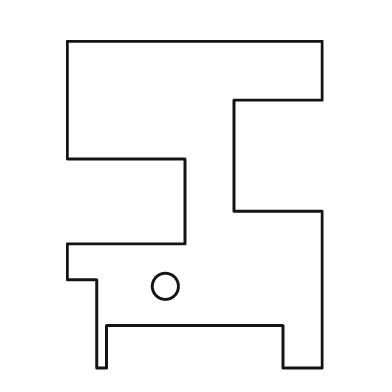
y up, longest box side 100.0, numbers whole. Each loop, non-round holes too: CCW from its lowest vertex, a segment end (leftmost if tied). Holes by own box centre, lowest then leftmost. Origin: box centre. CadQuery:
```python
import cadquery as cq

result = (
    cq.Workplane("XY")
    .moveTo(-30.0, -50.0)
    .lineTo(-27.0, -50.0)
    .lineTo(-27.0, -37.0)
    .lineTo(27.0, -37.0)
    .lineTo(27.0, -50.0)
    .lineTo(39.0, -50.0)
    .lineTo(39.0, -2.0)
    .lineTo(12.0, -2.0)
    .lineTo(12.0, 32.0)
    .lineTo(39.0, 32.0)
    .lineTo(39.0, 50.0)
    .lineTo(-39.0, 50.0)
    .lineTo(-39.0, 14.0)
    .lineTo(-3.0, 14.0)
    .lineTo(-3.0, -12.0)
    .lineTo(-39.0, -12.0)
    .lineTo(-39.0, -23.0)
    .lineTo(-30.0, -23.0)
    .close()
    .moveTo(-9.0, -25.0)
    .circle(4.0)
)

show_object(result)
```